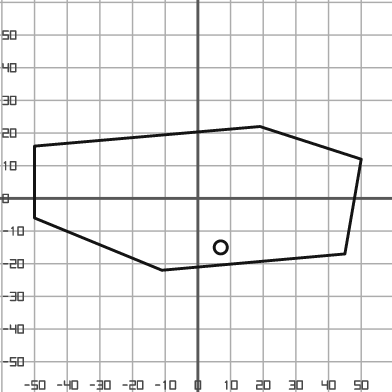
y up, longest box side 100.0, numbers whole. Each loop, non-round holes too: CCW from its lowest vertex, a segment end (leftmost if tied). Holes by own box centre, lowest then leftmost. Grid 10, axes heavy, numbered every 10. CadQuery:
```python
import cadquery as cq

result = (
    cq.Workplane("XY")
    .moveTo(-11.0, -22.0)
    .lineTo(45.0, -17.0)
    .lineTo(50.0, 12.0)
    .lineTo(19.0, 22.0)
    .lineTo(-50.0, 16.0)
    .lineTo(-50.0, -6.0)
    .close()
    .moveTo(7.0, -15.0)
    .circle(2.0)
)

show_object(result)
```